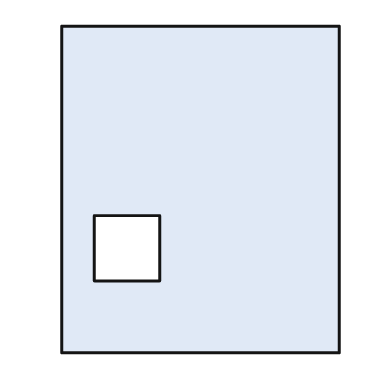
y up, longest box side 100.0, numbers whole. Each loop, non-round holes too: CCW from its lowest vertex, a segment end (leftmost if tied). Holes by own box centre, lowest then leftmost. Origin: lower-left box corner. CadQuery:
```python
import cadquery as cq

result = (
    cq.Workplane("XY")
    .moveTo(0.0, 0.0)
    .lineTo(85.0, 0.0)
    .lineTo(85.0, 100.0)
    .lineTo(0.0, 100.0)
    .close()
    .moveTo(10.0, 22.0)
    .lineTo(30.0, 22.0)
    .lineTo(30.0, 42.0)
    .lineTo(10.0, 42.0)
    .close()
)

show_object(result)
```